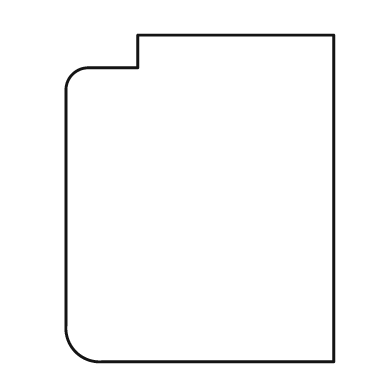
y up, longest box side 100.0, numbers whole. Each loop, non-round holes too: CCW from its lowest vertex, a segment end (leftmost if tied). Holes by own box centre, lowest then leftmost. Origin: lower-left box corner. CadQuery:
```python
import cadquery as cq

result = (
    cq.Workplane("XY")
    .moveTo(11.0, 0.0)
    .lineTo(82.0, 0.0)
    .lineTo(82.0, 100.0)
    .lineTo(22.0, 100.0)
    .lineTo(22.0, 90.0)
    .lineTo(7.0, 90.0)
    .threePointArc((2.0, 88.0), (0.0, 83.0))
    .lineTo(0.0, 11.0)
    .threePointArc((3.0, 3.0), (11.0, 0.0))
    .close()
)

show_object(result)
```